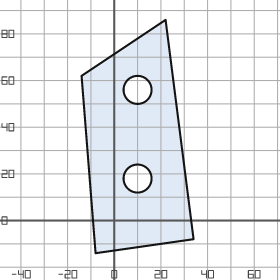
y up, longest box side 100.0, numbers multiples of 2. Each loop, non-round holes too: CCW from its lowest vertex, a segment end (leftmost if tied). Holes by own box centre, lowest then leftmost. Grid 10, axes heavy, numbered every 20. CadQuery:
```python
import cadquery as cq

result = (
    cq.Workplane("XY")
    .moveTo(-8.0, -14.0)
    .lineTo(34.0, -8.0)
    .lineTo(22.0, 86.0)
    .lineTo(-14.0, 62.0)
    .close()
    .moveTo(10.0, 18.0)
    .circle(6.0)
    .moveTo(10.0, 56.0)
    .circle(6.0)
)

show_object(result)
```